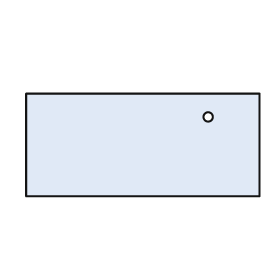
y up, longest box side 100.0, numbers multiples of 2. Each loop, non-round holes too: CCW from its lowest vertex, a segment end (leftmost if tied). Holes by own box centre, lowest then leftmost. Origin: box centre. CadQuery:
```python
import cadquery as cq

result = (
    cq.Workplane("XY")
    .moveTo(-50.0, -22.0)
    .lineTo(50.0, -22.0)
    .lineTo(50.0, 22.0)
    .lineTo(-50.0, 22.0)
    .close()
    .moveTo(28.0, 12.0)
    .circle(2.0)
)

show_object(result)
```